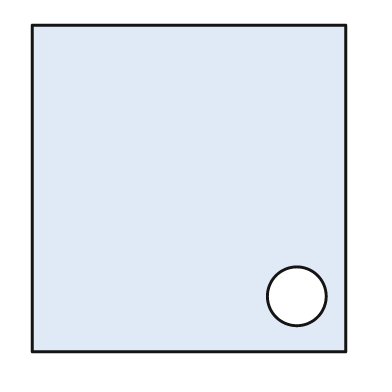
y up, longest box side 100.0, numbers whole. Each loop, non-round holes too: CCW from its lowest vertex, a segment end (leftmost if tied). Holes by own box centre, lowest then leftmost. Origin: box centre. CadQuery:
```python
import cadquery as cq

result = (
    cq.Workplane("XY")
    .moveTo(-48.0, -50.0)
    .lineTo(48.0, -50.0)
    .lineTo(48.0, 50.0)
    .lineTo(-48.0, 50.0)
    .close()
    .moveTo(33.0, -33.0)
    .circle(9.0)
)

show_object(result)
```